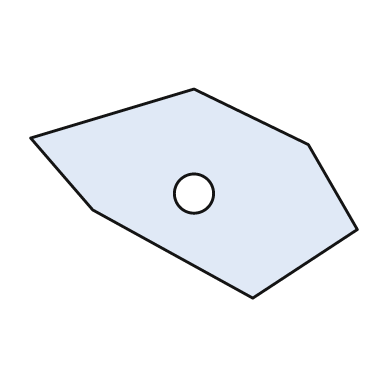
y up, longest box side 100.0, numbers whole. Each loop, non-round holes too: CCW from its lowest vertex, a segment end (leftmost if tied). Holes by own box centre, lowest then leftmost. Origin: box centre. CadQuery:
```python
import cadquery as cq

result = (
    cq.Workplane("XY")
    .moveTo(18.0, -32.0)
    .lineTo(50.0, -11.0)
    .lineTo(35.0, 15.0)
    .lineTo(0.0, 32.0)
    .lineTo(-50.0, 17.0)
    .lineTo(-31.0, -5.0)
    .close()
    .moveTo(0.0, 0.0)
    .circle(6.0)
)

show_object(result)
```